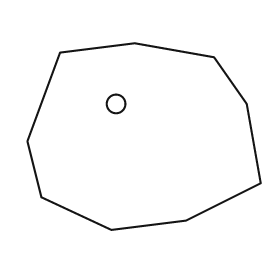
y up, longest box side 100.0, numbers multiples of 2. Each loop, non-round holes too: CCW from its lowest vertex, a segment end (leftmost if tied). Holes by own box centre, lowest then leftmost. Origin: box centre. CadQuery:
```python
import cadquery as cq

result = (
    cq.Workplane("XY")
    .moveTo(-14.0, -40.0)
    .lineTo(18.0, -36.0)
    .lineTo(50.0, -20.0)
    .lineTo(44.0, 14.0)
    .lineTo(30.0, 34.0)
    .lineTo(-4.0, 40.0)
    .lineTo(-36.0, 36.0)
    .lineTo(-50.0, -2.0)
    .lineTo(-44.0, -26.0)
    .close()
    .moveTo(-12.0, 14.0)
    .circle(4.0)
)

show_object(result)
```